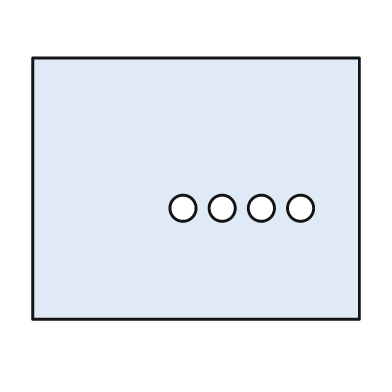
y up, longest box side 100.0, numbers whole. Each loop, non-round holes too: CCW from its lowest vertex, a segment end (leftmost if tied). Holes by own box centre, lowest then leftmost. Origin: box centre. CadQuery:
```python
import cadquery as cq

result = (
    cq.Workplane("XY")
    .moveTo(-50.0, -40.0)
    .lineTo(50.0, -40.0)
    .lineTo(50.0, 40.0)
    .lineTo(-50.0, 40.0)
    .close()
    .moveTo(-4.0, -6.0)
    .circle(4.0)
    .moveTo(8.0, -6.0)
    .circle(4.0)
    .moveTo(20.0, -6.0)
    .circle(4.0)
    .moveTo(32.0, -6.0)
    .circle(4.0)
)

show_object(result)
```